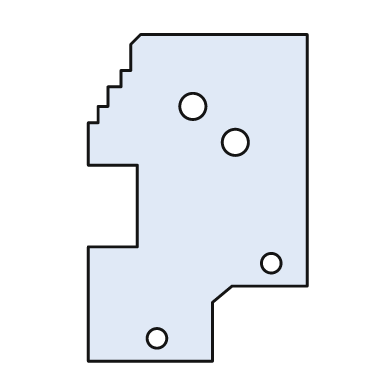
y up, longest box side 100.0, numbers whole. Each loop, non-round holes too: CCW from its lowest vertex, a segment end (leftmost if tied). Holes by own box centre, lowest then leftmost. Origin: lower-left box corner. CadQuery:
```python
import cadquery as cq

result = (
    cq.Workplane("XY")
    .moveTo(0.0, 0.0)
    .lineTo(38.0, 0.0)
    .lineTo(38.0, 18.0)
    .lineTo(44.0, 23.0)
    .lineTo(67.0, 23.0)
    .lineTo(67.0, 100.0)
    .lineTo(16.0, 100.0)
    .lineTo(13.0, 97.0)
    .lineTo(13.0, 89.0)
    .lineTo(10.0, 89.0)
    .lineTo(10.0, 84.0)
    .lineTo(6.0, 84.0)
    .lineTo(6.0, 78.0)
    .lineTo(3.0, 78.0)
    .lineTo(3.0, 73.0)
    .lineTo(0.0, 73.0)
    .lineTo(0.0, 60.0)
    .lineTo(15.0, 60.0)
    .lineTo(15.0, 35.0)
    .lineTo(0.0, 35.0)
    .close()
    .moveTo(21.0, 7.0)
    .circle(3.0)
    .moveTo(56.0, 30.0)
    .circle(3.0)
    .moveTo(45.0, 67.0)
    .circle(4.0)
    .moveTo(32.0, 78.0)
    .circle(4.0)
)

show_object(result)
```